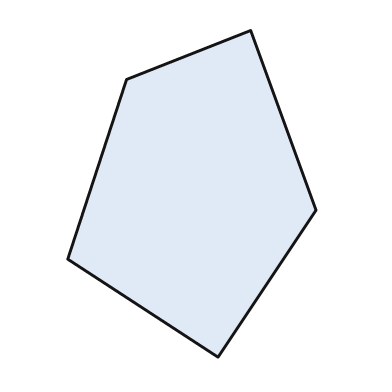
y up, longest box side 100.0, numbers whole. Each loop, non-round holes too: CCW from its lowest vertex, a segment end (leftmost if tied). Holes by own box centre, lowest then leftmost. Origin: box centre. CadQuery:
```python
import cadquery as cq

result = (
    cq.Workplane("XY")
    .moveTo(8.0, -50.0)
    .lineTo(38.0, -5.0)
    .lineTo(18.0, 50.0)
    .lineTo(-20.0, 35.0)
    .lineTo(-38.0, -20.0)
    .close()
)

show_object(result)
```